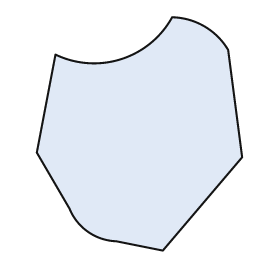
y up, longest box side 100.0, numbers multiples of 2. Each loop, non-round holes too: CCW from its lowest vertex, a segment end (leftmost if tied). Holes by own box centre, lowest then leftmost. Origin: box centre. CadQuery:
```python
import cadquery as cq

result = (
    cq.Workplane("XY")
    .moveTo(10.0, -50.0)
    .lineTo(44.0, -10.0)
    .lineTo(38.0, 36.0)
    .threePointArc((28.0, 46.0), (14.0, 50.0))
    .threePointArc((-8.0, 32.0), (-36.0, 34.0))
    .lineTo(-44.0, -8.0)
    .lineTo(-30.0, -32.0)
    .threePointArc((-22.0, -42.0), (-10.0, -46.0))
    .close()
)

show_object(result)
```